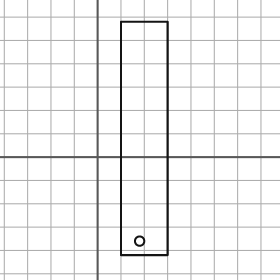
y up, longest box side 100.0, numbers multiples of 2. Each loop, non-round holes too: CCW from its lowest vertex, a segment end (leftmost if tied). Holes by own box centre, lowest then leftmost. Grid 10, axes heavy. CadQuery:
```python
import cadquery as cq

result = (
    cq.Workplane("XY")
    .moveTo(10.0, -42.0)
    .lineTo(30.0, -42.0)
    .lineTo(30.0, 58.0)
    .lineTo(10.0, 58.0)
    .close()
    .moveTo(18.0, -36.0)
    .circle(2.0)
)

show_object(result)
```